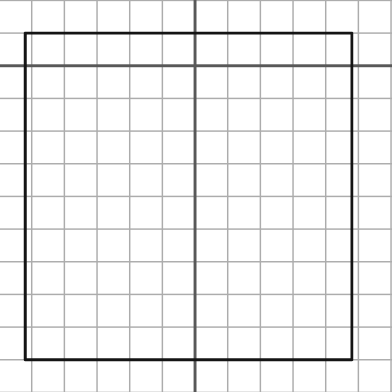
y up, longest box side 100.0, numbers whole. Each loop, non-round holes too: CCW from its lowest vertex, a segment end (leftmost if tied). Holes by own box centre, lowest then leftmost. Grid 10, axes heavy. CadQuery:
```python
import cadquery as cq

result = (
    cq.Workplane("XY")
    .moveTo(-52.0, -90.0)
    .lineTo(48.0, -90.0)
    .lineTo(48.0, 10.0)
    .lineTo(-52.0, 10.0)
    .close()
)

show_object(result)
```